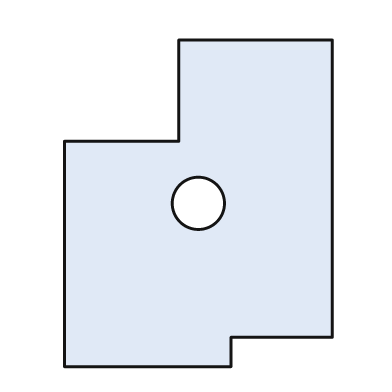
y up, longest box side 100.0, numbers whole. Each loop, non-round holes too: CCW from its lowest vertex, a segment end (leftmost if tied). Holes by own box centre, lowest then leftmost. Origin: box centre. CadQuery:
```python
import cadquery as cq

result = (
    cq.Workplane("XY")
    .moveTo(-41.0, -50.0)
    .lineTo(10.0, -50.0)
    .lineTo(10.0, -41.0)
    .lineTo(41.0, -41.0)
    .lineTo(41.0, 50.0)
    .lineTo(-6.0, 50.0)
    .lineTo(-6.0, 19.0)
    .lineTo(-41.0, 19.0)
    .close()
    .moveTo(0.0, 0.0)
    .circle(8.0)
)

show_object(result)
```